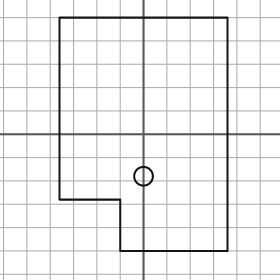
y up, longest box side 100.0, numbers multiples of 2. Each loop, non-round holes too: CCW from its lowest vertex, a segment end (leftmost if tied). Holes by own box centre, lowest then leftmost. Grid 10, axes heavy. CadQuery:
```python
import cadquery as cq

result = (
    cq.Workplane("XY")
    .moveTo(-10.0, -50.0)
    .lineTo(36.0, -50.0)
    .lineTo(36.0, 50.0)
    .lineTo(-36.0, 50.0)
    .lineTo(-36.0, -28.0)
    .lineTo(-10.0, -28.0)
    .close()
    .moveTo(0.0, -18.0)
    .circle(4.0)
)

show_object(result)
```